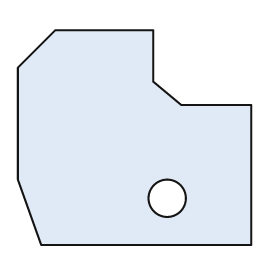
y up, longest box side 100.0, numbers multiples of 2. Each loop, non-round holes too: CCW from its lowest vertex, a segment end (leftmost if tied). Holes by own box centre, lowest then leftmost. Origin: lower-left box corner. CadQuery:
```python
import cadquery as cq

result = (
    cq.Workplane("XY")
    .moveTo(10.0, 0.0)
    .lineTo(100.0, 0.0)
    .lineTo(100.0, 60.0)
    .lineTo(70.0, 60.0)
    .lineTo(58.0, 70.0)
    .lineTo(58.0, 92.0)
    .lineTo(16.0, 92.0)
    .lineTo(0.0, 76.0)
    .lineTo(0.0, 28.0)
    .close()
    .moveTo(64.0, 20.0)
    .circle(8.0)
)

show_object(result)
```